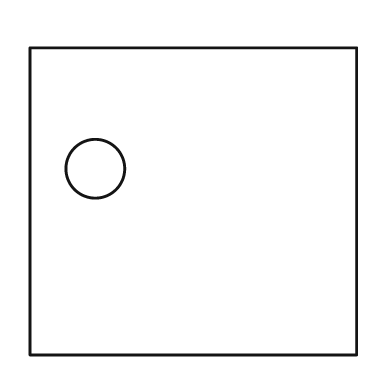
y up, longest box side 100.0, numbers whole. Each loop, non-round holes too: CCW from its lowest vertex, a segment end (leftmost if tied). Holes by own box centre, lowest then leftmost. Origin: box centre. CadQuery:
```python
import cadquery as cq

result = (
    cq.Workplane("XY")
    .moveTo(-50.0, -47.0)
    .lineTo(50.0, -47.0)
    .lineTo(50.0, 47.0)
    .lineTo(-50.0, 47.0)
    .close()
    .moveTo(-30.0, 10.0)
    .circle(9.0)
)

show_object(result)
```